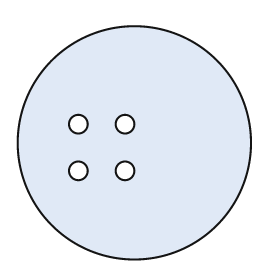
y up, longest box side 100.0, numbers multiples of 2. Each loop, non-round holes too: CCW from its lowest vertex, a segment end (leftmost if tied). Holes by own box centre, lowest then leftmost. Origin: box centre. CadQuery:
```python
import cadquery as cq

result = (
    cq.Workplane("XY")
    .moveTo(0.0, 0.0)
    .circle(50.0)
    .moveTo(-24.0, -12.0)
    .circle(4.0)
    .moveTo(-4.0, -12.0)
    .circle(4.0)
    .moveTo(-24.0, 8.0)
    .circle(4.0)
    .moveTo(-4.0, 8.0)
    .circle(4.0)
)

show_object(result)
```